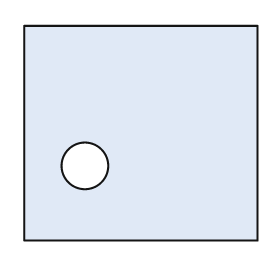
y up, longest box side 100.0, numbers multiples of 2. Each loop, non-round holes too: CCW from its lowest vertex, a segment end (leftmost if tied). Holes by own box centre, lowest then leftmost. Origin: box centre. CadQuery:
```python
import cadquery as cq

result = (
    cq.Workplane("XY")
    .moveTo(-50.0, -46.0)
    .lineTo(50.0, -46.0)
    .lineTo(50.0, 46.0)
    .lineTo(-50.0, 46.0)
    .close()
    .moveTo(-24.0, -14.0)
    .circle(10.0)
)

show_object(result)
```